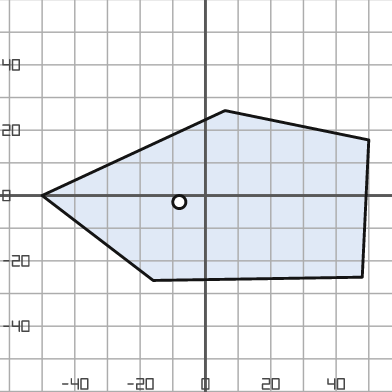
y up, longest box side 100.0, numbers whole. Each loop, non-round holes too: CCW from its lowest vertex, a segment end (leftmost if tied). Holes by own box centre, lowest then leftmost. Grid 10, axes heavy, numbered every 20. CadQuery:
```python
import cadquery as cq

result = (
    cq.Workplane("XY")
    .moveTo(-16.0, -26.0)
    .lineTo(48.0, -25.0)
    .lineTo(50.0, 17.0)
    .lineTo(6.0, 26.0)
    .lineTo(-50.0, 0.0)
    .close()
    .moveTo(-8.0, -2.0)
    .circle(2.0)
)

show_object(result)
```